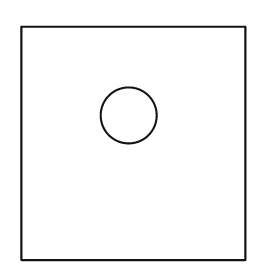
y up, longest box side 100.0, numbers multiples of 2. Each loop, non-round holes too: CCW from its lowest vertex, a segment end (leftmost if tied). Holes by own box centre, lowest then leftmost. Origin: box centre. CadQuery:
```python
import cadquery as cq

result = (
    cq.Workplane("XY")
    .moveTo(-48.0, -50.0)
    .lineTo(48.0, -50.0)
    .lineTo(48.0, 50.0)
    .lineTo(-48.0, 50.0)
    .close()
    .moveTo(-2.0, 12.0)
    .circle(12.0)
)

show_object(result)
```